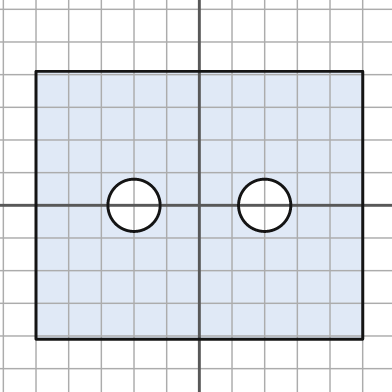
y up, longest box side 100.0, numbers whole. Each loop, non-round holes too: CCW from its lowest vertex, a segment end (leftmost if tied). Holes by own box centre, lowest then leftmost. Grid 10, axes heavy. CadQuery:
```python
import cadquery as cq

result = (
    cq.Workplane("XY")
    .moveTo(-50.0, -41.0)
    .lineTo(50.0, -41.0)
    .lineTo(50.0, 41.0)
    .lineTo(-50.0, 41.0)
    .close()
    .moveTo(-20.0, 0.0)
    .circle(8.0)
    .moveTo(20.0, 0.0)
    .circle(8.0)
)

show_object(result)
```